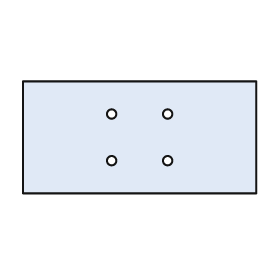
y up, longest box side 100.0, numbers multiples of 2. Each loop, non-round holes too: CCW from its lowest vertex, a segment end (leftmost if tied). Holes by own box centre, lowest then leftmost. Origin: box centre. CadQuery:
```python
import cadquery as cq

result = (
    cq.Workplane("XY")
    .moveTo(-50.0, -24.0)
    .lineTo(50.0, -24.0)
    .lineTo(50.0, 24.0)
    .lineTo(-50.0, 24.0)
    .close()
    .moveTo(-12.0, -10.0)
    .circle(2.0)
    .moveTo(12.0, -10.0)
    .circle(2.0)
    .moveTo(-12.0, 10.0)
    .circle(2.0)
    .moveTo(12.0, 10.0)
    .circle(2.0)
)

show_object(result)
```